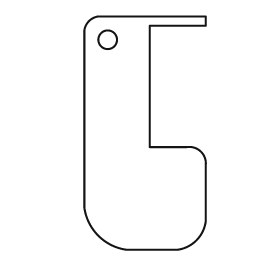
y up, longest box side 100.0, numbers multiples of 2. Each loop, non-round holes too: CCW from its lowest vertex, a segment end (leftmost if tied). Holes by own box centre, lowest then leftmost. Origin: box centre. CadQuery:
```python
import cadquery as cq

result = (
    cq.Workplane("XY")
    .moveTo(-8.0, -50.0)
    .lineTo(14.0, -50.0)
    .threePointArc((22.0, -46.0), (26.0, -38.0))
    .lineTo(26.0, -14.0)
    .threePointArc((24.0, -8.0), (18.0, -6.0))
    .lineTo(2.0, -6.0)
    .lineTo(2.0, 46.0)
    .lineTo(26.0, 46.0)
    .lineTo(26.0, 50.0)
    .lineTo(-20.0, 50.0)
    .threePointArc((-24.0, 48.0), (-26.0, 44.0))
    .lineTo(-26.0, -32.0)
    .threePointArc((-20.0, -44.0), (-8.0, -50.0))
    .close()
    .moveTo(-16.0, 40.0)
    .circle(4.0)
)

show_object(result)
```